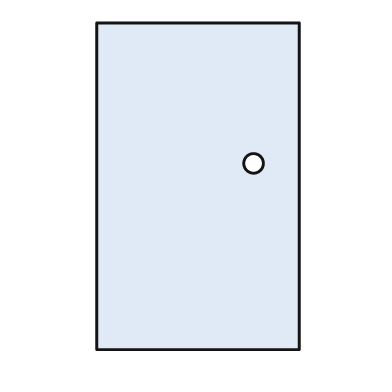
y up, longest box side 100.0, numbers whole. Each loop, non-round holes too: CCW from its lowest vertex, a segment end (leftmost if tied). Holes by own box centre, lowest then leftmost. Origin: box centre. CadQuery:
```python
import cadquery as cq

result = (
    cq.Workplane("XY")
    .moveTo(-31.0, -50.0)
    .lineTo(31.0, -50.0)
    .lineTo(31.0, 50.0)
    .lineTo(-31.0, 50.0)
    .close()
    .moveTo(17.0, 7.0)
    .circle(3.0)
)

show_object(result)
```